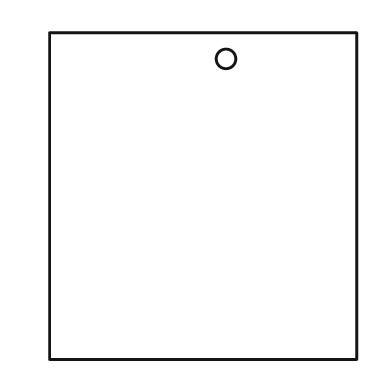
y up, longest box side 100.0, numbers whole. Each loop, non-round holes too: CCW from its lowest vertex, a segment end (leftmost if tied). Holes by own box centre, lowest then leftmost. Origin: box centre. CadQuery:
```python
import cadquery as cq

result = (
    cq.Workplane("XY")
    .moveTo(-47.0, -50.0)
    .lineTo(47.0, -50.0)
    .lineTo(47.0, 50.0)
    .lineTo(-47.0, 50.0)
    .close()
    .moveTo(7.0, 42.0)
    .circle(3.0)
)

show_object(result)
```